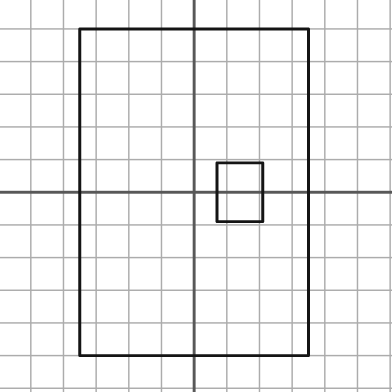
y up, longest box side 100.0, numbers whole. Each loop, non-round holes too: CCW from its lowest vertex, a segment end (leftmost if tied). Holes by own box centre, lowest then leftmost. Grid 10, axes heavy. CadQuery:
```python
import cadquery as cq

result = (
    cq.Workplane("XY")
    .moveTo(-35.0, -50.0)
    .lineTo(35.0, -50.0)
    .lineTo(35.0, 50.0)
    .lineTo(-35.0, 50.0)
    .close()
    .moveTo(7.0, -9.0)
    .lineTo(21.0, -9.0)
    .lineTo(21.0, 9.0)
    .lineTo(7.0, 9.0)
    .close()
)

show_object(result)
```